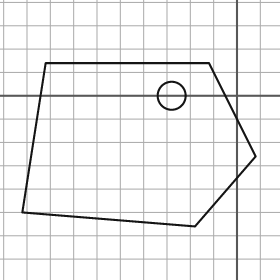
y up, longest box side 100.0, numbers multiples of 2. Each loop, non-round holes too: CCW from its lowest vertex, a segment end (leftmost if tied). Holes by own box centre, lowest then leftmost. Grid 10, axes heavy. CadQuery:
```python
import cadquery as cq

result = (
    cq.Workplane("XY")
    .moveTo(-18.0, -56.0)
    .lineTo(8.0, -26.0)
    .lineTo(-12.0, 14.0)
    .lineTo(-82.0, 14.0)
    .lineTo(-92.0, -50.0)
    .close()
    .moveTo(-28.0, 0.0)
    .circle(6.0)
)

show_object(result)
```